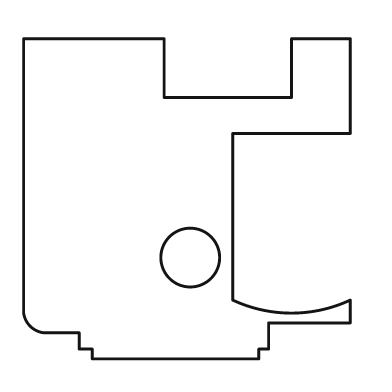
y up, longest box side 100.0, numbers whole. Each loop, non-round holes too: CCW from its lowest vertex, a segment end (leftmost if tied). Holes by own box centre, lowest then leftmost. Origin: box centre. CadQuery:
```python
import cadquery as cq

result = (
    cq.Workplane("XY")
    .moveTo(-29.0, -49.0)
    .lineTo(22.0, -49.0)
    .lineTo(22.0, -46.0)
    .lineTo(25.0, -46.0)
    .lineTo(25.0, -38.0)
    .lineTo(50.0, -38.0)
    .lineTo(50.0, -31.0)
    .threePointArc((32.0, -35.0), (14.0, -31.0))
    .lineTo(14.0, 20.0)
    .lineTo(50.0, 20.0)
    .lineTo(50.0, 49.0)
    .lineTo(32.0, 49.0)
    .lineTo(32.0, 31.0)
    .lineTo(-7.0, 31.0)
    .lineTo(-7.0, 49.0)
    .lineTo(-50.0, 49.0)
    .lineTo(-50.0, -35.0)
    .threePointArc((-48.0, -39.0), (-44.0, -41.0))
    .lineTo(-33.0, -41.0)
    .lineTo(-33.0, -46.0)
    .lineTo(-29.0, -46.0)
    .close()
    .moveTo(1.0, -18.0)
    .circle(9.0)
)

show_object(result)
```